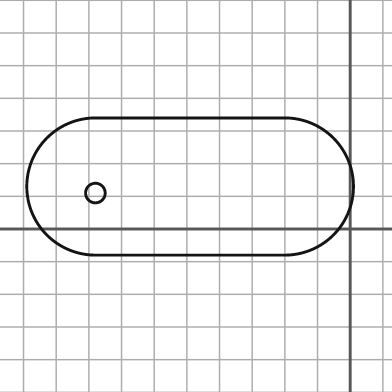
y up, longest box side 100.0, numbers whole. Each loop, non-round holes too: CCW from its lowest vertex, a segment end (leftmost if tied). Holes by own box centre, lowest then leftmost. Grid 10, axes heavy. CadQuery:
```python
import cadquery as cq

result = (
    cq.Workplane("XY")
    .moveTo(-78.0, -8.0)
    .lineTo(-20.0, -8.0)
    .threePointArc((1.0, 13.0), (-20.0, 34.0))
    .lineTo(-78.0, 34.0)
    .threePointArc((-99.0, 13.0), (-78.0, -8.0))
    .close()
    .moveTo(-78.0, 11.0)
    .circle(3.0)
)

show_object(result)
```